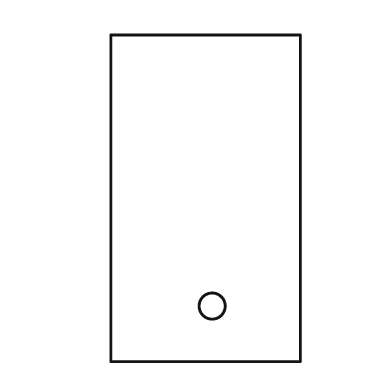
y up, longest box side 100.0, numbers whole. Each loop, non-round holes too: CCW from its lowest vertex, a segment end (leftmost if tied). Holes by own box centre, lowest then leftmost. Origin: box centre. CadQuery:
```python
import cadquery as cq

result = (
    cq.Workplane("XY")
    .moveTo(-29.0, -50.0)
    .lineTo(29.0, -50.0)
    .lineTo(29.0, 50.0)
    .lineTo(-29.0, 50.0)
    .close()
    .moveTo(2.0, -33.0)
    .circle(4.0)
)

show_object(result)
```